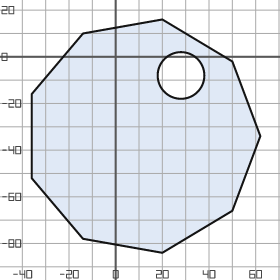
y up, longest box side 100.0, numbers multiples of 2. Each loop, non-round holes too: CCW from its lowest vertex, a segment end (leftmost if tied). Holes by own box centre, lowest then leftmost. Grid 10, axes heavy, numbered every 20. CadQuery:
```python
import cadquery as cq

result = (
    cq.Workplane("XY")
    .moveTo(20.0, -84.0)
    .lineTo(50.0, -66.0)
    .lineTo(62.0, -34.0)
    .lineTo(50.0, -2.0)
    .lineTo(20.0, 16.0)
    .lineTo(-14.0, 10.0)
    .lineTo(-36.0, -16.0)
    .lineTo(-36.0, -52.0)
    .lineTo(-14.0, -78.0)
    .close()
    .moveTo(28.0, -8.0)
    .circle(10.0)
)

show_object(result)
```